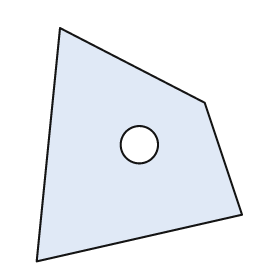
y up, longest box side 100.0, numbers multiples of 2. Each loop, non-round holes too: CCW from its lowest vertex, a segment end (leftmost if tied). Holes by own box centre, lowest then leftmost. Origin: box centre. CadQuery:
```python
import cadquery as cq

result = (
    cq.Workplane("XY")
    .moveTo(-44.0, -50.0)
    .lineTo(44.0, -30.0)
    .lineTo(28.0, 18.0)
    .lineTo(-34.0, 50.0)
    .close()
    .moveTo(0.0, 0.0)
    .circle(8.0)
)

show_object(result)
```